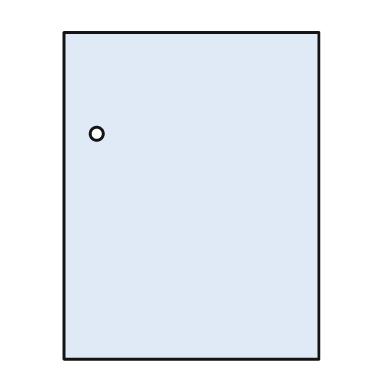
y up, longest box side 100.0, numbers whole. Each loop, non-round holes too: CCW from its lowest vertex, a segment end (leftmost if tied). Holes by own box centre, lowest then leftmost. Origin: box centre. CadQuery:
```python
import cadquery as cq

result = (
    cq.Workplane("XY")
    .moveTo(-39.0, -50.0)
    .lineTo(39.0, -50.0)
    .lineTo(39.0, 50.0)
    .lineTo(-39.0, 50.0)
    .close()
    .moveTo(-29.0, 19.0)
    .circle(2.0)
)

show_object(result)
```